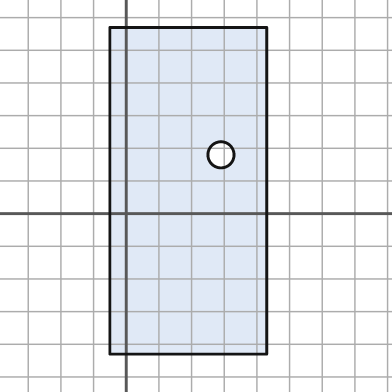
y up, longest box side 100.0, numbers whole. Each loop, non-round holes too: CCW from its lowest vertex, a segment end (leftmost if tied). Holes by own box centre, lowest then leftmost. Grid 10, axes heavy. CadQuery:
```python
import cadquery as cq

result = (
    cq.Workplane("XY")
    .moveTo(-5.0, -43.0)
    .lineTo(43.0, -43.0)
    .lineTo(43.0, 57.0)
    .lineTo(-5.0, 57.0)
    .close()
    .moveTo(29.0, 18.0)
    .circle(4.0)
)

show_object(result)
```